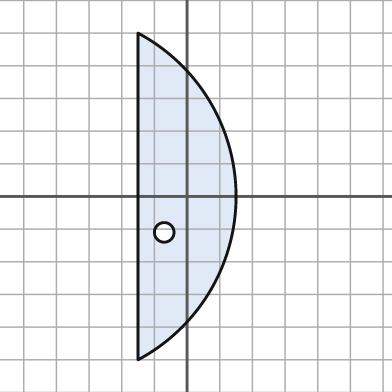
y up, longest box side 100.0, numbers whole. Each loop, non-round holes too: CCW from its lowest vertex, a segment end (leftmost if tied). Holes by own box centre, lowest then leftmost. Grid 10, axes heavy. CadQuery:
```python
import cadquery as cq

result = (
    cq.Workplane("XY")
    .moveTo(-15.0, -50.0)
    .threePointArc((15.0, 0.0), (-15.0, 50.0))
    .close()
    .moveTo(-7.0, -11.0)
    .circle(3.0)
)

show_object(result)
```